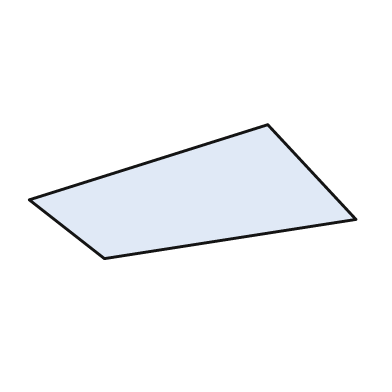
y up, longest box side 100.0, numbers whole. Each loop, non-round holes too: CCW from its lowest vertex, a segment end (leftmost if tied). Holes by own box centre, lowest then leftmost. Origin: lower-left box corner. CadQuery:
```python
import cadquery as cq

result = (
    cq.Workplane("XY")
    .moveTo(23.0, 0.0)
    .lineTo(100.0, 12.0)
    .lineTo(73.0, 41.0)
    .lineTo(0.0, 18.0)
    .close()
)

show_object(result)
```